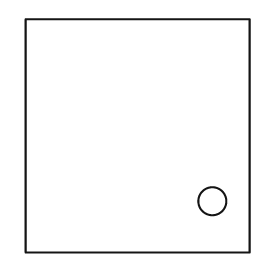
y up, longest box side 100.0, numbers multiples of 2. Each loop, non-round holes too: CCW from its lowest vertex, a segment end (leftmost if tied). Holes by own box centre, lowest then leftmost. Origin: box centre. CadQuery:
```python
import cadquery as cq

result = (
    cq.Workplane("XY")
    .moveTo(-48.0, -50.0)
    .lineTo(48.0, -50.0)
    .lineTo(48.0, 50.0)
    .lineTo(-48.0, 50.0)
    .close()
    .moveTo(32.0, -28.0)
    .circle(6.0)
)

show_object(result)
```